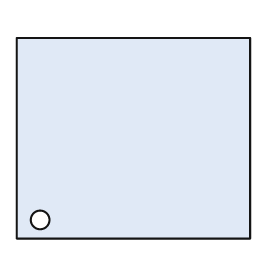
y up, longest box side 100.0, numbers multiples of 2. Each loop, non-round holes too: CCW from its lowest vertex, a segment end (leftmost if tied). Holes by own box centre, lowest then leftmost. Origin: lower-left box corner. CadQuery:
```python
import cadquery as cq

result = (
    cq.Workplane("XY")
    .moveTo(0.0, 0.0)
    .lineTo(100.0, 0.0)
    .lineTo(100.0, 86.0)
    .lineTo(0.0, 86.0)
    .close()
    .moveTo(10.0, 8.0)
    .circle(4.0)
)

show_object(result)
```